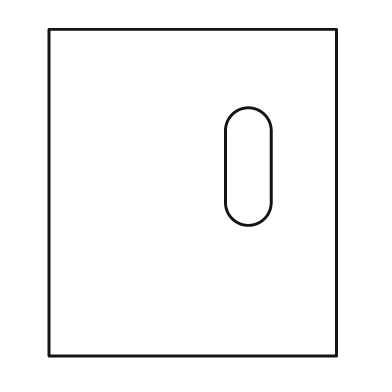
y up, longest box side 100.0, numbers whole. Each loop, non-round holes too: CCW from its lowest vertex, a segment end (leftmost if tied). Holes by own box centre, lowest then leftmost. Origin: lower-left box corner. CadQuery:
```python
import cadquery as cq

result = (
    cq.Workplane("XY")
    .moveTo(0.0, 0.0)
    .lineTo(88.0, 0.0)
    .lineTo(88.0, 100.0)
    .lineTo(0.0, 100.0)
    .close()
    .moveTo(54.0, 47.0)
    .threePointArc((61.0, 40.0), (68.0, 47.0))
    .lineTo(68.0, 69.0)
    .threePointArc((61.0, 76.0), (54.0, 69.0))
    .close()
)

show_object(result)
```